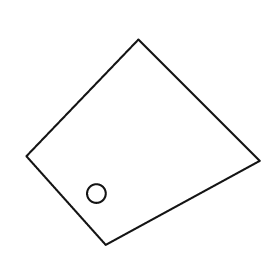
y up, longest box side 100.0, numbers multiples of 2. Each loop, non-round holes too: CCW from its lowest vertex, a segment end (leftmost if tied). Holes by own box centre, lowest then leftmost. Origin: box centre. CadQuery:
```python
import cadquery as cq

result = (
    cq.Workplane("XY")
    .moveTo(-16.0, -44.0)
    .lineTo(50.0, -8.0)
    .lineTo(-2.0, 44.0)
    .lineTo(-50.0, -6.0)
    .close()
    .moveTo(-20.0, -22.0)
    .circle(4.0)
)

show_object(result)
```